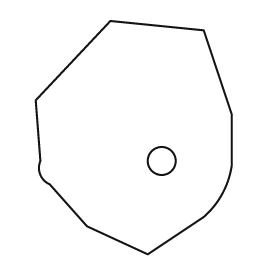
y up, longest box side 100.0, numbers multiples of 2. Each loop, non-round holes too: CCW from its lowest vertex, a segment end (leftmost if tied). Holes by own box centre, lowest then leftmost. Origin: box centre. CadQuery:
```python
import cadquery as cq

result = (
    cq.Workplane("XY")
    .moveTo(6.0, -50.0)
    .lineTo(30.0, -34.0)
    .threePointArc((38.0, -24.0), (42.0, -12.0))
    .lineTo(42.0, 10.0)
    .lineTo(30.0, 46.0)
    .lineTo(-10.0, 50.0)
    .lineTo(-42.0, 16.0)
    .lineTo(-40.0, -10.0)
    .threePointArc((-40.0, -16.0), (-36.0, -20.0))
    .lineTo(-20.0, -38.0)
    .close()
    .moveTo(12.0, -10.0)
    .circle(6.0)
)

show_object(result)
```